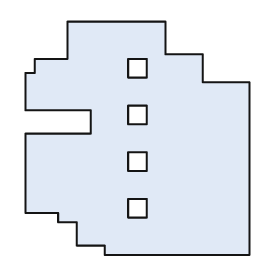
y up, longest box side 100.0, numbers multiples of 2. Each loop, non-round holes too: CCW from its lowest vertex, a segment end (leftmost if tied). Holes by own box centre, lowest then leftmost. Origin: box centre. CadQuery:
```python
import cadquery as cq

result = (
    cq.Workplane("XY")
    .moveTo(-14.0, -50.0)
    .lineTo(48.0, -50.0)
    .lineTo(48.0, 24.0)
    .lineTo(28.0, 24.0)
    .lineTo(28.0, 36.0)
    .lineTo(12.0, 36.0)
    .lineTo(12.0, 50.0)
    .lineTo(-30.0, 50.0)
    .lineTo(-30.0, 34.0)
    .lineTo(-44.0, 34.0)
    .lineTo(-44.0, 28.0)
    .lineTo(-48.0, 28.0)
    .lineTo(-48.0, 12.0)
    .lineTo(-20.0, 12.0)
    .lineTo(-20.0, 2.0)
    .lineTo(-48.0, 2.0)
    .lineTo(-48.0, -32.0)
    .lineTo(-34.0, -32.0)
    .lineTo(-34.0, -36.0)
    .lineTo(-26.0, -36.0)
    .lineTo(-26.0, -46.0)
    .lineTo(-14.0, -46.0)
    .close()
    .moveTo(-4.0, -34.0)
    .lineTo(4.0, -34.0)
    .lineTo(4.0, -26.0)
    .lineTo(-4.0, -26.0)
    .close()
    .moveTo(-4.0, -14.0)
    .lineTo(4.0, -14.0)
    .lineTo(4.0, -6.0)
    .lineTo(-4.0, -6.0)
    .close()
    .moveTo(-4.0, 6.0)
    .lineTo(4.0, 6.0)
    .lineTo(4.0, 14.0)
    .lineTo(-4.0, 14.0)
    .close()
    .moveTo(-4.0, 26.0)
    .lineTo(4.0, 26.0)
    .lineTo(4.0, 34.0)
    .lineTo(-4.0, 34.0)
    .close()
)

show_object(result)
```